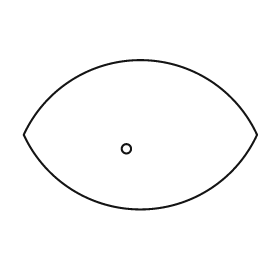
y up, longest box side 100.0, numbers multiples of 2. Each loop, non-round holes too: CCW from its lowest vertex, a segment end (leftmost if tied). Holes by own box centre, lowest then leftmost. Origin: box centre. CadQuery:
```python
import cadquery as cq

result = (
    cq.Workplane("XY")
    .moveTo(-50.0, 0.0)
    .threePointArc((0.0, -32.0), (50.0, 0.0))
    .threePointArc((0.0, 32.0), (-50.0, 0.0))
    .close()
    .moveTo(-6.0, -6.0)
    .circle(2.0)
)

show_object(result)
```